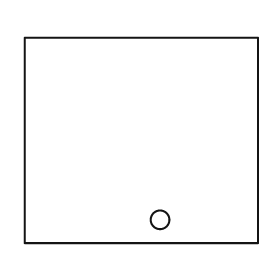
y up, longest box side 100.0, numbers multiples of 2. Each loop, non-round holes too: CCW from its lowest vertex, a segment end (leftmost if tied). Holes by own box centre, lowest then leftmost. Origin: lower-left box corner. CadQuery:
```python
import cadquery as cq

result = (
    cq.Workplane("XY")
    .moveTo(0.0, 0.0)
    .lineTo(100.0, 0.0)
    .lineTo(100.0, 88.0)
    .lineTo(0.0, 88.0)
    .close()
    .moveTo(58.0, 10.0)
    .circle(4.0)
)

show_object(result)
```